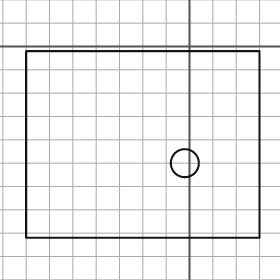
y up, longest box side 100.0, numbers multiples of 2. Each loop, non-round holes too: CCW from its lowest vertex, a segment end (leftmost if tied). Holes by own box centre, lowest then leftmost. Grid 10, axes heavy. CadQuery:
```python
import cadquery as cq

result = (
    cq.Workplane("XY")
    .moveTo(-70.0, -82.0)
    .lineTo(30.0, -82.0)
    .lineTo(30.0, -2.0)
    .lineTo(-70.0, -2.0)
    .close()
    .moveTo(-2.0, -50.0)
    .circle(6.0)
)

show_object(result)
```